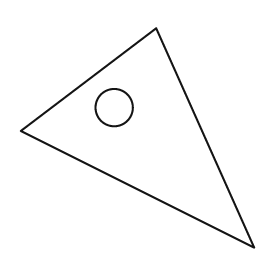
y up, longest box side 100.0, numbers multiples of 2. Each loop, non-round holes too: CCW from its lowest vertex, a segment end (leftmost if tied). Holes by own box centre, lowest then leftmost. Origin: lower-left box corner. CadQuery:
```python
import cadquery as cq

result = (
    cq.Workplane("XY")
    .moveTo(100.0, 0.0)
    .lineTo(58.0, 94.0)
    .lineTo(0.0, 50.0)
    .close()
    .moveTo(40.0, 60.0)
    .circle(8.0)
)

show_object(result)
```